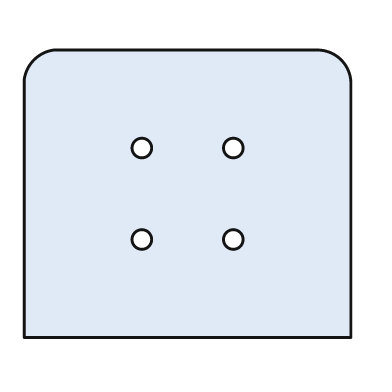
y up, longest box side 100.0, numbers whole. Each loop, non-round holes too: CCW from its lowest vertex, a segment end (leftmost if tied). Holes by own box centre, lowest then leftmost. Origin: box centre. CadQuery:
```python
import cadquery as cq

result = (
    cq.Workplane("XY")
    .moveTo(-50.0, -44.0)
    .lineTo(50.0, -44.0)
    .lineTo(50.0, 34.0)
    .threePointArc((47.0, 41.0), (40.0, 44.0))
    .lineTo(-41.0, 44.0)
    .threePointArc((-47.0, 41.0), (-50.0, 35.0))
    .close()
    .moveTo(-14.0, -14.0)
    .circle(3.0)
    .moveTo(14.0, -14.0)
    .circle(3.0)
    .moveTo(-14.0, 14.0)
    .circle(3.0)
    .moveTo(14.0, 14.0)
    .circle(3.0)
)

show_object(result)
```